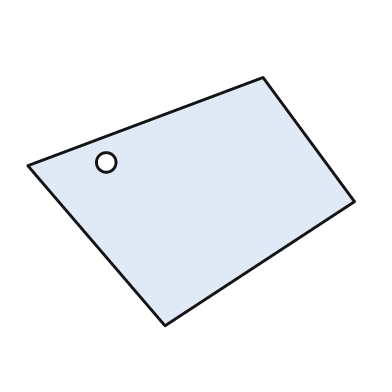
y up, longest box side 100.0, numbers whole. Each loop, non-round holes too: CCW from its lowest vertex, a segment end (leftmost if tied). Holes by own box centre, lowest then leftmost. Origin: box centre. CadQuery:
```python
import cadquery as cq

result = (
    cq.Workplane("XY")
    .moveTo(-8.0, -38.0)
    .lineTo(50.0, 0.0)
    .lineTo(22.0, 38.0)
    .lineTo(-50.0, 11.0)
    .close()
    .moveTo(-26.0, 12.0)
    .circle(3.0)
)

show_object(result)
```